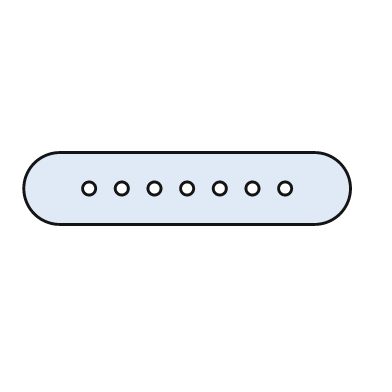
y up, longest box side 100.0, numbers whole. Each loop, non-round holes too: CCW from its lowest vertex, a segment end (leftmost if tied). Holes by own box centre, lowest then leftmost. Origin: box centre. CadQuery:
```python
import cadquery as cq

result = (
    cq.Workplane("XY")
    .moveTo(-39.0, -11.0)
    .lineTo(39.0, -11.0)
    .threePointArc((50.0, 0.0), (39.0, 11.0))
    .lineTo(-39.0, 11.0)
    .threePointArc((-50.0, 0.0), (-39.0, -11.0))
    .close()
    .moveTo(-30.0, 0.0)
    .circle(2.0)
    .moveTo(-20.0, 0.0)
    .circle(2.0)
    .moveTo(-10.0, 0.0)
    .circle(2.0)
    .moveTo(0.0, 0.0)
    .circle(2.0)
    .moveTo(10.0, 0.0)
    .circle(2.0)
    .moveTo(20.0, 0.0)
    .circle(2.0)
    .moveTo(30.0, 0.0)
    .circle(2.0)
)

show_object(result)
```